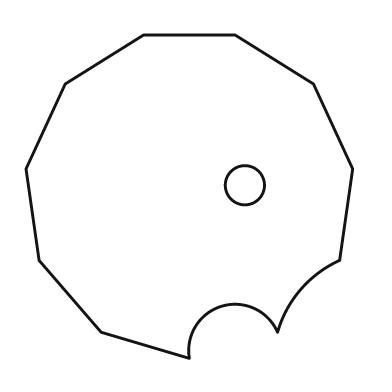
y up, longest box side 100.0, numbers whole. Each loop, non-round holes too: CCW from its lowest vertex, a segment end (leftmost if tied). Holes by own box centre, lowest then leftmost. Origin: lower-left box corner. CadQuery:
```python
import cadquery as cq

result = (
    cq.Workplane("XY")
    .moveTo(50.0, 0.0)
    .threePointArc((60.0, 16.0), (77.0, 8.0))
    .threePointArc((84.0, 21.0), (96.0, 30.0))
    .lineTo(100.0, 58.0)
    .lineTo(88.0, 84.0)
    .lineTo(64.0, 99.0)
    .lineTo(36.0, 99.0)
    .lineTo(12.0, 84.0)
    .lineTo(0.0, 58.0)
    .lineTo(4.0, 30.0)
    .lineTo(23.0, 8.0)
    .close()
    .moveTo(67.0, 53.0)
    .circle(6.0)
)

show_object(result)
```